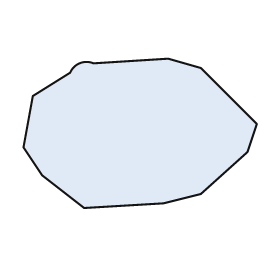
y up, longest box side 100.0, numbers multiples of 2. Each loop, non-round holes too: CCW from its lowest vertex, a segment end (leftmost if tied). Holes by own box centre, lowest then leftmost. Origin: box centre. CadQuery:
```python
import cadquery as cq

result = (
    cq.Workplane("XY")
    .moveTo(-24.0, -32.0)
    .lineTo(10.0, -30.0)
    .lineTo(26.0, -26.0)
    .lineTo(46.0, -8.0)
    .lineTo(50.0, 4.0)
    .lineTo(26.0, 28.0)
    .lineTo(12.0, 32.0)
    .lineTo(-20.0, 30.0)
    .threePointArc((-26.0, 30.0), (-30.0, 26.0))
    .lineTo(-46.0, 16.0)
    .lineTo(-50.0, -6.0)
    .lineTo(-42.0, -18.0)
    .close()
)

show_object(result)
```